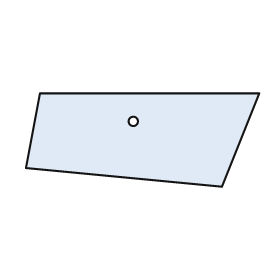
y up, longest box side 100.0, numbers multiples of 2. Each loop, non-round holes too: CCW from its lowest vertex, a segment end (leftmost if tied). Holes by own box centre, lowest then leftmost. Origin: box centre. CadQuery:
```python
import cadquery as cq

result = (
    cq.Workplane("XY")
    .moveTo(34.0, -20.0)
    .lineTo(50.0, 20.0)
    .lineTo(-44.0, 20.0)
    .lineTo(-50.0, -12.0)
    .close()
    .moveTo(-4.0, 8.0)
    .circle(2.0)
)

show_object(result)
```